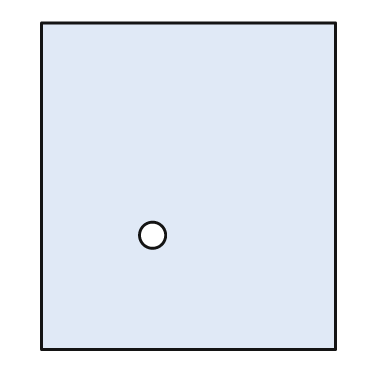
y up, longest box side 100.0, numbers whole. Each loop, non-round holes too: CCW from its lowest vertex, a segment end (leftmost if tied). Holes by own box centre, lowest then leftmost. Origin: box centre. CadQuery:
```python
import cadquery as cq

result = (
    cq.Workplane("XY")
    .moveTo(-45.0, -50.0)
    .lineTo(45.0, -50.0)
    .lineTo(45.0, 50.0)
    .lineTo(-45.0, 50.0)
    .close()
    .moveTo(-11.0, -15.0)
    .circle(4.0)
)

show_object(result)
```